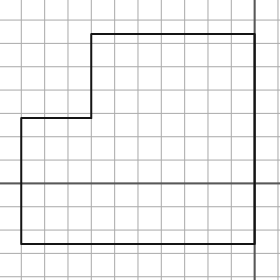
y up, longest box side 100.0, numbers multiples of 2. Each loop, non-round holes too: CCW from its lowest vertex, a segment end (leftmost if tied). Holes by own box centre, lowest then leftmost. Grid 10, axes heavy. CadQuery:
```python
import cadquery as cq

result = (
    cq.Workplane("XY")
    .moveTo(-100.0, -26.0)
    .lineTo(0.0, -26.0)
    .lineTo(0.0, 64.0)
    .lineTo(-70.0, 64.0)
    .lineTo(-70.0, 28.0)
    .lineTo(-100.0, 28.0)
    .close()
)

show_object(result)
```